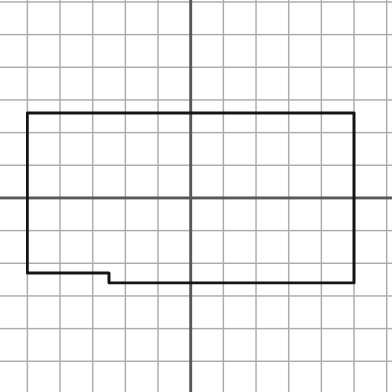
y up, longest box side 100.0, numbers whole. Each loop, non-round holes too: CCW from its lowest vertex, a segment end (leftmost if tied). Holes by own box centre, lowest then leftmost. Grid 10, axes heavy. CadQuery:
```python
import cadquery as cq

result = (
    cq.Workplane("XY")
    .moveTo(-25.0, -26.0)
    .lineTo(50.0, -26.0)
    .lineTo(50.0, 26.0)
    .lineTo(-50.0, 26.0)
    .lineTo(-50.0, -23.0)
    .lineTo(-25.0, -23.0)
    .close()
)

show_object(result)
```